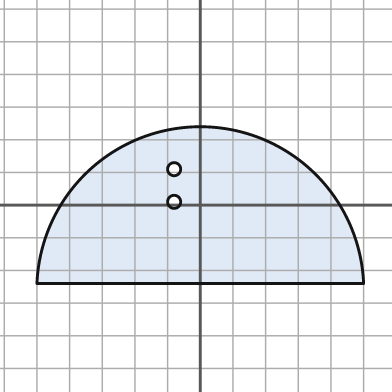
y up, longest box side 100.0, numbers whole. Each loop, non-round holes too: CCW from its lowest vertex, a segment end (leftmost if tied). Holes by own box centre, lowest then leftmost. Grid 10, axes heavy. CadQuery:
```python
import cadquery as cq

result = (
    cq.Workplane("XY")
    .moveTo(-50.0, -24.0)
    .lineTo(50.0, -24.0)
    .threePointArc((0.0, 24.0), (-50.0, -24.0))
    .close()
    .moveTo(-8.0, 1.0)
    .circle(2.0)
    .moveTo(-8.0, 11.0)
    .circle(2.0)
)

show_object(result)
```